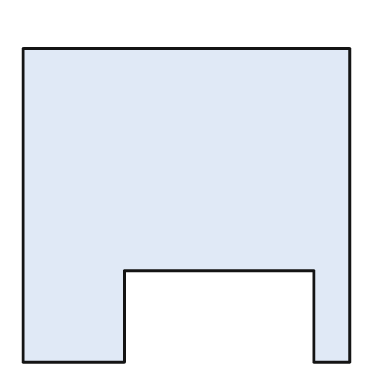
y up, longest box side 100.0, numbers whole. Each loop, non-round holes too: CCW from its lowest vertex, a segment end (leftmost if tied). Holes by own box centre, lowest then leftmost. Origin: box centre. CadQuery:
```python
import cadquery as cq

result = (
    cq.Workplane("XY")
    .moveTo(-50.0, -48.0)
    .lineTo(-19.0, -48.0)
    .lineTo(-19.0, -20.0)
    .lineTo(39.0, -20.0)
    .lineTo(39.0, -48.0)
    .lineTo(50.0, -48.0)
    .lineTo(50.0, 48.0)
    .lineTo(-50.0, 48.0)
    .close()
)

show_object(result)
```